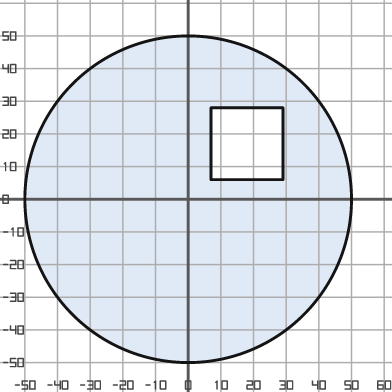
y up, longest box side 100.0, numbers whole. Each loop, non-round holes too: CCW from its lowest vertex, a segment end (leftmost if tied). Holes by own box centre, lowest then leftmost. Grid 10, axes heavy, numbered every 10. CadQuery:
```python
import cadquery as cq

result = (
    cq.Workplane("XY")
    .moveTo(0.0, 0.0)
    .circle(50.0)
    .moveTo(7.0, 6.0)
    .lineTo(29.0, 6.0)
    .lineTo(29.0, 28.0)
    .lineTo(7.0, 28.0)
    .close()
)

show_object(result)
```